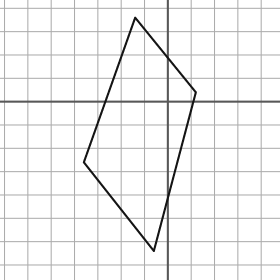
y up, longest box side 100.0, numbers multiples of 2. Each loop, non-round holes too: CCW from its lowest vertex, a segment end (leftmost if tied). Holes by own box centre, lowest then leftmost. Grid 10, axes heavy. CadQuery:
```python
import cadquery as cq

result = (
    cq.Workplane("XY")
    .moveTo(-6.0, -64.0)
    .lineTo(12.0, 4.0)
    .lineTo(-14.0, 36.0)
    .lineTo(-36.0, -26.0)
    .close()
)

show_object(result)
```